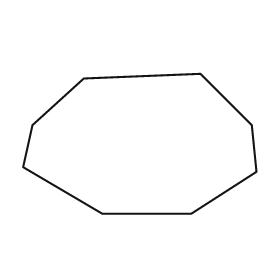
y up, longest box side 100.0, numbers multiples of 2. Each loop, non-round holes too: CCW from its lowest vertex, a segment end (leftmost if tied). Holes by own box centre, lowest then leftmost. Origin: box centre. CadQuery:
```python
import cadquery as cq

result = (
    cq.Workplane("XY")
    .moveTo(-16.0, -30.0)
    .lineTo(22.0, -30.0)
    .lineTo(50.0, -12.0)
    .lineTo(48.0, 8.0)
    .lineTo(26.0, 30.0)
    .lineTo(-24.0, 28.0)
    .lineTo(-46.0, 8.0)
    .lineTo(-50.0, -10.0)
    .close()
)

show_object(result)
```